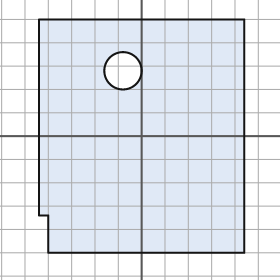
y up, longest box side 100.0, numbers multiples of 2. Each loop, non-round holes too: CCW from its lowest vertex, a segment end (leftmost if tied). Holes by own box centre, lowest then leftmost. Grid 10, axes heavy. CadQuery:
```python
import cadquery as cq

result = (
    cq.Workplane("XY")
    .moveTo(-40.0, -50.0)
    .lineTo(44.0, -50.0)
    .lineTo(44.0, 50.0)
    .lineTo(-44.0, 50.0)
    .lineTo(-44.0, -34.0)
    .lineTo(-40.0, -34.0)
    .close()
    .moveTo(-8.0, 28.0)
    .circle(8.0)
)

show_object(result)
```